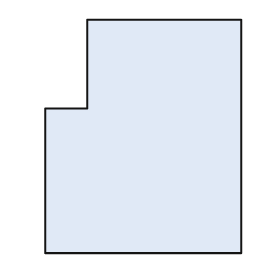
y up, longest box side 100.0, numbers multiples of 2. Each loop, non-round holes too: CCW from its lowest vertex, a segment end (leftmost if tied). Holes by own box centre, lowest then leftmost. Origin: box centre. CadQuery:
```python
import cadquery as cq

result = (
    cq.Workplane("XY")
    .moveTo(-42.0, -50.0)
    .lineTo(42.0, -50.0)
    .lineTo(42.0, 50.0)
    .lineTo(-24.0, 50.0)
    .lineTo(-24.0, 12.0)
    .lineTo(-42.0, 12.0)
    .close()
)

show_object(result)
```